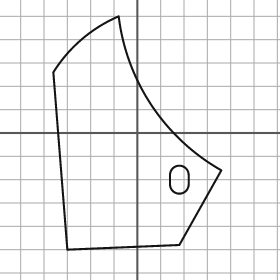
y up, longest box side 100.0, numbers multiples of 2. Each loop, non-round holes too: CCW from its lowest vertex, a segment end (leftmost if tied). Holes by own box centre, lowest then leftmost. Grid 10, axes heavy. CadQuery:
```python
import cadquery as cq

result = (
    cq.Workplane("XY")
    .moveTo(-30.0, -50.0)
    .lineTo(18.0, -48.0)
    .lineTo(36.0, -16.0)
    .threePointArc((6.0, 12.0), (-8.0, 50.0))
    .threePointArc((-24.0, 40.0), (-36.0, 26.0))
    .close()
    .moveTo(14.0, -22.0)
    .threePointArc((18.0, -26.0), (22.0, -22.0))
    .lineTo(22.0, -18.0)
    .threePointArc((18.0, -14.0), (14.0, -18.0))
    .close()
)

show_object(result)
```